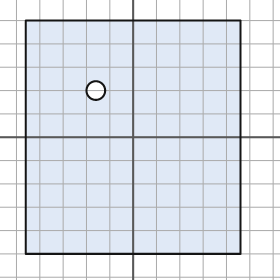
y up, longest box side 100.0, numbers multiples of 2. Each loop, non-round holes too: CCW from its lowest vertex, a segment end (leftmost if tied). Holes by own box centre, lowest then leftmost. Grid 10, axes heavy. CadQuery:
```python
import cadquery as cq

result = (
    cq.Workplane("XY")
    .moveTo(-46.0, -50.0)
    .lineTo(46.0, -50.0)
    .lineTo(46.0, 50.0)
    .lineTo(-46.0, 50.0)
    .close()
    .moveTo(-16.0, 20.0)
    .circle(4.0)
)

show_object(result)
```